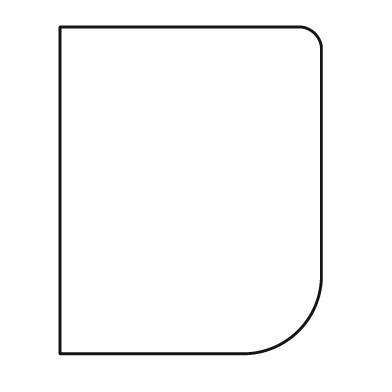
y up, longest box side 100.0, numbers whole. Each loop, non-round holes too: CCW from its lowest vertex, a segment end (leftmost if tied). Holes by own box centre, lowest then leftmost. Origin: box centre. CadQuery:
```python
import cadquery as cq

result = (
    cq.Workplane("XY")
    .moveTo(-40.0, -50.0)
    .lineTo(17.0, -50.0)
    .threePointArc((33.0, -43.0), (40.0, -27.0))
    .lineTo(40.0, 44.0)
    .threePointArc((38.0, 48.0), (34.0, 50.0))
    .lineTo(-40.0, 50.0)
    .close()
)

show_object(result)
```